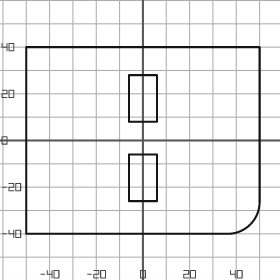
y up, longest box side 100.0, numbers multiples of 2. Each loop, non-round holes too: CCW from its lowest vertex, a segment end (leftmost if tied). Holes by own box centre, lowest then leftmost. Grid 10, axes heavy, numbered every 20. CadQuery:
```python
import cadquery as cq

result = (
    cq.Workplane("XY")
    .moveTo(-50.0, -40.0)
    .lineTo(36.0, -40.0)
    .threePointArc((46.0, -36.0), (50.0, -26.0))
    .lineTo(50.0, 40.0)
    .lineTo(-50.0, 40.0)
    .close()
    .moveTo(-6.0, -26.0)
    .lineTo(6.0, -26.0)
    .lineTo(6.0, -6.0)
    .lineTo(-6.0, -6.0)
    .close()
    .moveTo(-6.0, 8.0)
    .lineTo(6.0, 8.0)
    .lineTo(6.0, 28.0)
    .lineTo(-6.0, 28.0)
    .close()
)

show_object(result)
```